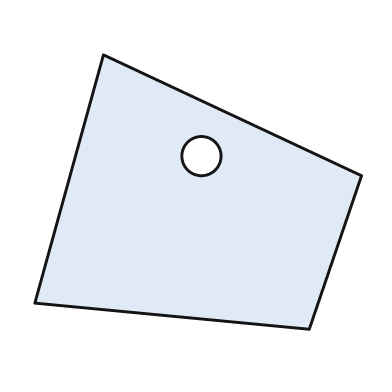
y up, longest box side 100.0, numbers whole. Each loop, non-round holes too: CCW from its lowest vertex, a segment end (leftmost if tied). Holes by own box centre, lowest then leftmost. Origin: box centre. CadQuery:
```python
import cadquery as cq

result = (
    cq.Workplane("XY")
    .moveTo(34.0, -42.0)
    .lineTo(50.0, 5.0)
    .lineTo(-29.0, 42.0)
    .lineTo(-50.0, -34.0)
    .close()
    .moveTo(1.0, 11.0)
    .circle(6.0)
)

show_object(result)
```